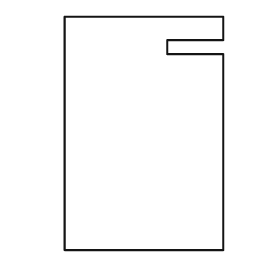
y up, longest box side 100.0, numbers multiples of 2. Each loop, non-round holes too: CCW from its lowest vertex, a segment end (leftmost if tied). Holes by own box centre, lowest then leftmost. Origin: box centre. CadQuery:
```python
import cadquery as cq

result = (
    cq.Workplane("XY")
    .moveTo(-34.0, -50.0)
    .lineTo(34.0, -50.0)
    .lineTo(34.0, 34.0)
    .lineTo(10.0, 34.0)
    .lineTo(10.0, 40.0)
    .lineTo(34.0, 40.0)
    .lineTo(34.0, 50.0)
    .lineTo(-34.0, 50.0)
    .close()
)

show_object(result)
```